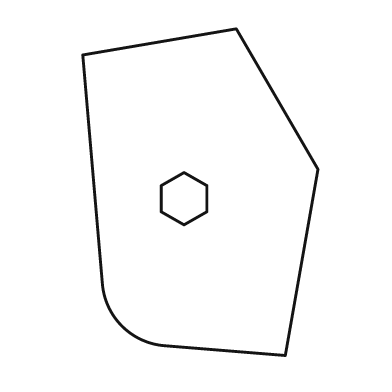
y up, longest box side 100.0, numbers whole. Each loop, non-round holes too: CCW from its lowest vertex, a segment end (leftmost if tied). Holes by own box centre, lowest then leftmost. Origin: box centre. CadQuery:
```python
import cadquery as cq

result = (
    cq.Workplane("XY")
    .moveTo(26.0, -50.0)
    .lineTo(36.0, 7.0)
    .lineTo(11.0, 50.0)
    .lineTo(-36.0, 42.0)
    .lineTo(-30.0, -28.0)
    .threePointArc((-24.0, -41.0), (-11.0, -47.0))
    .close()
    .moveTo(-5.0, -10.0)
    .lineTo(2.0, -6.0)
    .lineTo(2.0, 2.0)
    .lineTo(-5.0, 6.0)
    .lineTo(-12.0, 2.0)
    .lineTo(-12.0, -6.0)
    .close()
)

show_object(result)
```